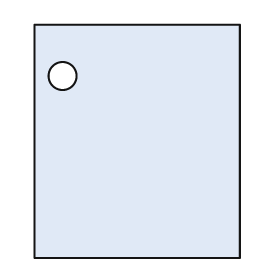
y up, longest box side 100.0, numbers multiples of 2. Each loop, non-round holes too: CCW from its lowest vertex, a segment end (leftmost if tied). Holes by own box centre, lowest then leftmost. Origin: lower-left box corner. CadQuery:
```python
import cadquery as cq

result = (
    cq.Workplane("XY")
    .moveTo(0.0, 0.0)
    .lineTo(88.0, 0.0)
    .lineTo(88.0, 100.0)
    .lineTo(0.0, 100.0)
    .close()
    .moveTo(12.0, 78.0)
    .circle(6.0)
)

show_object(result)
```